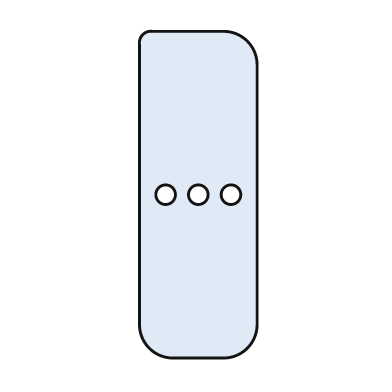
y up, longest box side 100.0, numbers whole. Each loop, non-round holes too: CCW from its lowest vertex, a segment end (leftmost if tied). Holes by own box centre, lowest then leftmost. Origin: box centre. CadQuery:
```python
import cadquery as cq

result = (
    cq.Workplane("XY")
    .moveTo(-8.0, -50.0)
    .lineTo(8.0, -50.0)
    .threePointArc((15.0, -47.0), (18.0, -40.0))
    .lineTo(18.0, 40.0)
    .threePointArc((15.0, 47.0), (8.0, 50.0))
    .lineTo(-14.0, 50.0)
    .threePointArc((-17.0, 49.0), (-18.0, 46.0))
    .lineTo(-18.0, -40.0)
    .threePointArc((-15.0, -47.0), (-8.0, -50.0))
    .close()
    .moveTo(-10.0, 0.0)
    .circle(3.0)
    .moveTo(0.0, 0.0)
    .circle(3.0)
    .moveTo(10.0, 0.0)
    .circle(3.0)
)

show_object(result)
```